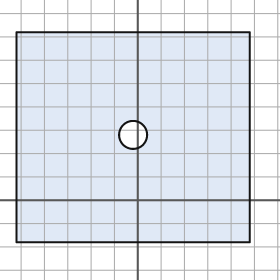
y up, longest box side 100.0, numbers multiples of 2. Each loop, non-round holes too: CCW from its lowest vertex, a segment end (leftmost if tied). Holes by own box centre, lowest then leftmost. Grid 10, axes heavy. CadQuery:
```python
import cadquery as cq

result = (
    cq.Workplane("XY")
    .moveTo(-52.0, -18.0)
    .lineTo(48.0, -18.0)
    .lineTo(48.0, 72.0)
    .lineTo(-52.0, 72.0)
    .close()
    .moveTo(-2.0, 28.0)
    .circle(6.0)
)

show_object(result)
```